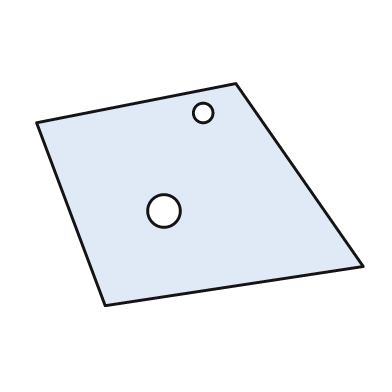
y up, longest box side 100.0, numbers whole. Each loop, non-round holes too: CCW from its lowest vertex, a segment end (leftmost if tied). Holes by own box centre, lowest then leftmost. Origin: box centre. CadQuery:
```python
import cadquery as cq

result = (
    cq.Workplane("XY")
    .moveTo(-29.0, -34.0)
    .lineTo(50.0, -22.0)
    .lineTo(11.0, 34.0)
    .lineTo(-50.0, 22.0)
    .close()
    .moveTo(-11.0, -5.0)
    .circle(5.0)
    .moveTo(1.0, 25.0)
    .circle(3.0)
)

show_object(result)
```